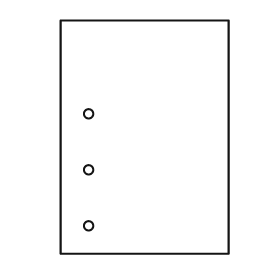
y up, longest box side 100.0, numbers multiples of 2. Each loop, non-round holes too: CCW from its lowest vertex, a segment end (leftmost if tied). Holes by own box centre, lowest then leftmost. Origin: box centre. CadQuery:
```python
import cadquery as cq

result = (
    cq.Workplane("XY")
    .moveTo(-36.0, -50.0)
    .lineTo(36.0, -50.0)
    .lineTo(36.0, 50.0)
    .lineTo(-36.0, 50.0)
    .close()
    .moveTo(-24.0, -38.0)
    .circle(2.0)
    .moveTo(-24.0, -14.0)
    .circle(2.0)
    .moveTo(-24.0, 10.0)
    .circle(2.0)
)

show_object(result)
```